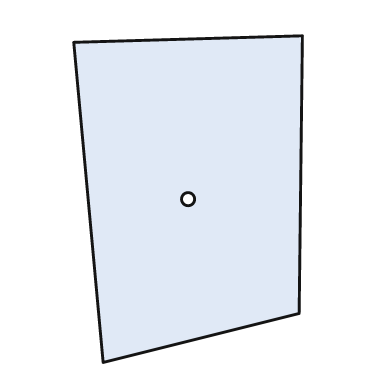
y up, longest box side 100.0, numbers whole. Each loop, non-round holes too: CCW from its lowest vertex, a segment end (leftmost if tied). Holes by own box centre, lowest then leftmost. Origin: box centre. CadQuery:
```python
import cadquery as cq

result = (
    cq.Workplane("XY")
    .moveTo(-26.0, -50.0)
    .lineTo(34.0, -35.0)
    .lineTo(35.0, 50.0)
    .lineTo(-35.0, 48.0)
    .close()
    .moveTo(0.0, 0.0)
    .circle(2.0)
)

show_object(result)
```